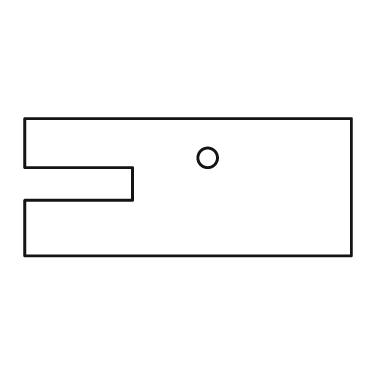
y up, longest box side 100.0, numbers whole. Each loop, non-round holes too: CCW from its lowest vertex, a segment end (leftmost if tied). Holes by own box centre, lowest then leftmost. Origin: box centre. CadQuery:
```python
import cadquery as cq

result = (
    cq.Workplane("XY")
    .moveTo(-50.0, -21.0)
    .lineTo(50.0, -21.0)
    .lineTo(50.0, 21.0)
    .lineTo(-50.0, 21.0)
    .lineTo(-50.0, 6.0)
    .lineTo(-17.0, 6.0)
    .lineTo(-17.0, -4.0)
    .lineTo(-50.0, -4.0)
    .close()
    .moveTo(6.0, 9.0)
    .circle(3.0)
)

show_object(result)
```